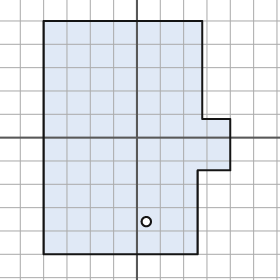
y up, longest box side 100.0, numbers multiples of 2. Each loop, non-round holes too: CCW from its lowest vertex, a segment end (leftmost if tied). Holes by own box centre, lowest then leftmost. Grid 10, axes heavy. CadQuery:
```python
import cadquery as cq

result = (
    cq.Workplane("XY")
    .moveTo(-40.0, -50.0)
    .lineTo(26.0, -50.0)
    .lineTo(26.0, -14.0)
    .lineTo(40.0, -14.0)
    .lineTo(40.0, 8.0)
    .lineTo(28.0, 8.0)
    .lineTo(28.0, 50.0)
    .lineTo(-40.0, 50.0)
    .close()
    .moveTo(4.0, -36.0)
    .circle(2.0)
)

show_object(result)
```